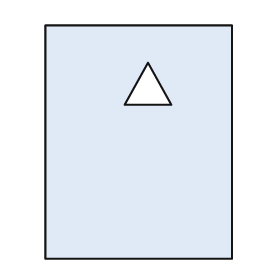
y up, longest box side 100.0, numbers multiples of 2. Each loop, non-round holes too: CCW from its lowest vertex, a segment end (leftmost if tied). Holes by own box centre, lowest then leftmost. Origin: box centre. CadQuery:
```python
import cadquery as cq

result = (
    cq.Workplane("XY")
    .moveTo(-40.0, -50.0)
    .lineTo(40.0, -50.0)
    .lineTo(40.0, 50.0)
    .lineTo(-40.0, 50.0)
    .close()
    .moveTo(-6.0, 16.0)
    .lineTo(14.0, 16.0)
    .lineTo(4.0, 34.0)
    .close()
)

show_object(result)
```